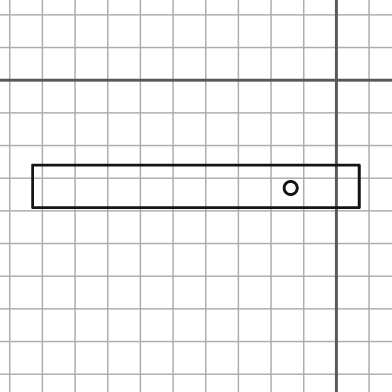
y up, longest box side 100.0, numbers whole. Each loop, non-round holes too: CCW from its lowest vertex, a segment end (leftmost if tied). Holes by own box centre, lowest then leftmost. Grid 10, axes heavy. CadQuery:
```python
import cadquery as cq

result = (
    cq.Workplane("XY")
    .moveTo(-93.0, -39.0)
    .lineTo(7.0, -39.0)
    .lineTo(7.0, -26.0)
    .lineTo(-93.0, -26.0)
    .close()
    .moveTo(-14.0, -33.0)
    .circle(2.0)
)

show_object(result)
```